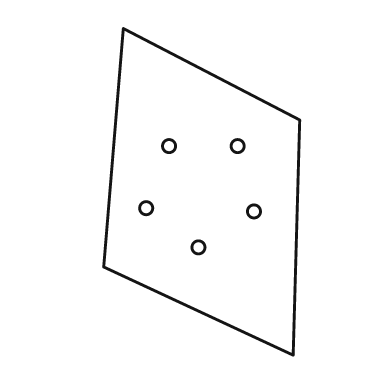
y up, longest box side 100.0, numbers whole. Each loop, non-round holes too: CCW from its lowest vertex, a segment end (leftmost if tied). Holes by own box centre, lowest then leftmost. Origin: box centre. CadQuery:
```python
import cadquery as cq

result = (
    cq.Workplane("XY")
    .moveTo(28.0, -50.0)
    .lineTo(30.0, 22.0)
    .lineTo(-24.0, 50.0)
    .lineTo(-30.0, -23.0)
    .close()
    .moveTo(-1.0, -17.0)
    .circle(2.0)
    .moveTo(16.0, -6.0)
    .circle(2.0)
    .moveTo(-17.0, -5.0)
    .circle(2.0)
    .moveTo(-10.0, 14.0)
    .circle(2.0)
    .moveTo(11.0, 14.0)
    .circle(2.0)
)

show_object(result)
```